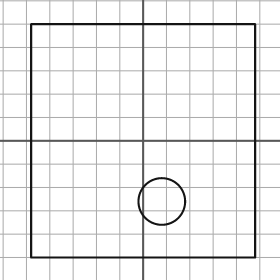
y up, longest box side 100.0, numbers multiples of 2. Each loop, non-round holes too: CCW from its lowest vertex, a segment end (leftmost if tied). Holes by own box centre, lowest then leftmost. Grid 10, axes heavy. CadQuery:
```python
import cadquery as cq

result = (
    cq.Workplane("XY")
    .moveTo(-48.0, -50.0)
    .lineTo(48.0, -50.0)
    .lineTo(48.0, 50.0)
    .lineTo(-48.0, 50.0)
    .close()
    .moveTo(8.0, -26.0)
    .circle(10.0)
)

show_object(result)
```